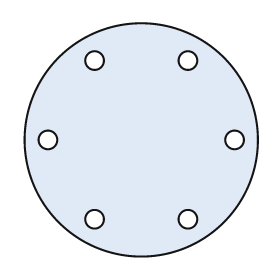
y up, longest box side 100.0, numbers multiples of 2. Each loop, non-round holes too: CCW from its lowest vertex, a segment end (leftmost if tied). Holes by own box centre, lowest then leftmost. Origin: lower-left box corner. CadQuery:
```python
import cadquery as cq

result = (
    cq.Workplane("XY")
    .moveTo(50.0, 50.0)
    .circle(50.0)
    .moveTo(30.0, 16.0)
    .circle(4.0)
    .moveTo(70.0, 16.0)
    .circle(4.0)
    .moveTo(10.0, 50.0)
    .circle(4.0)
    .moveTo(90.0, 50.0)
    .circle(4.0)
    .moveTo(30.0, 84.0)
    .circle(4.0)
    .moveTo(70.0, 84.0)
    .circle(4.0)
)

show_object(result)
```